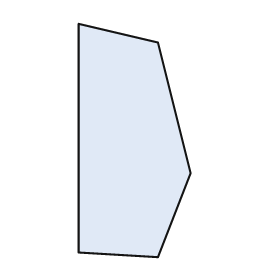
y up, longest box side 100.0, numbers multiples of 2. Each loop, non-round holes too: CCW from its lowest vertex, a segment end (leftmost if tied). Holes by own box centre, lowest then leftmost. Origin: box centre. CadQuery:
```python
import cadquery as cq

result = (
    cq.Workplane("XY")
    .moveTo(10.0, -50.0)
    .lineTo(24.0, -14.0)
    .lineTo(10.0, 42.0)
    .lineTo(-24.0, 50.0)
    .lineTo(-24.0, -48.0)
    .close()
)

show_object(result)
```